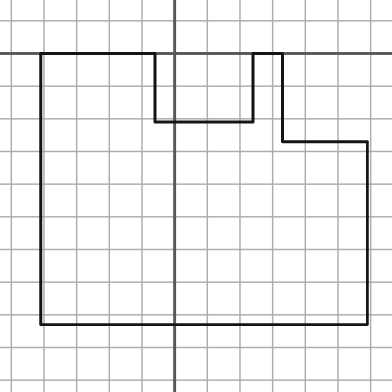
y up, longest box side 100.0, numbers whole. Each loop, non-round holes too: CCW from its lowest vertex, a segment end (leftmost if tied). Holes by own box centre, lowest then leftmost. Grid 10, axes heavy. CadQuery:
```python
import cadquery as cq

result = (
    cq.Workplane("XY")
    .moveTo(-41.0, -83.0)
    .lineTo(59.0, -83.0)
    .lineTo(59.0, -27.0)
    .lineTo(33.0, -27.0)
    .lineTo(33.0, 0.0)
    .lineTo(24.0, 0.0)
    .lineTo(24.0, -21.0)
    .lineTo(-6.0, -21.0)
    .lineTo(-6.0, 0.0)
    .lineTo(-41.0, 0.0)
    .close()
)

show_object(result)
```